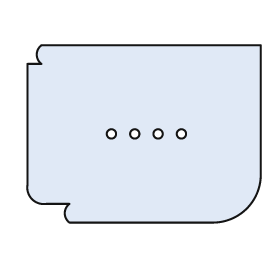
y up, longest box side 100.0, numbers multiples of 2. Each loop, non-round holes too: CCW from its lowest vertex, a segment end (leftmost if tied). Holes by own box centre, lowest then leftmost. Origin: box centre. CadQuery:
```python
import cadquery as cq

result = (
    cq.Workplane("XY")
    .moveTo(-32.0, -38.0)
    .lineTo(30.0, -38.0)
    .threePointArc((44.0, -32.0), (50.0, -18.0))
    .lineTo(50.0, 38.0)
    .lineTo(-44.0, 38.0)
    .threePointArc((-46.0, 34.0), (-44.0, 30.0))
    .lineTo(-50.0, 30.0)
    .lineTo(-50.0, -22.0)
    .threePointArc((-48.0, -28.0), (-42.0, -30.0))
    .lineTo(-32.0, -30.0)
    .threePointArc((-34.0, -34.0), (-32.0, -38.0))
    .close()
    .moveTo(-14.0, 0.0)
    .circle(2.0)
    .moveTo(-4.0, 0.0)
    .circle(2.0)
    .moveTo(6.0, 0.0)
    .circle(2.0)
    .moveTo(16.0, 0.0)
    .circle(2.0)
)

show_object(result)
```